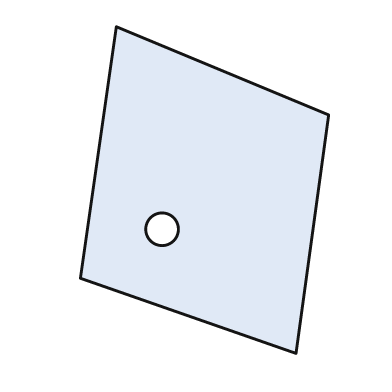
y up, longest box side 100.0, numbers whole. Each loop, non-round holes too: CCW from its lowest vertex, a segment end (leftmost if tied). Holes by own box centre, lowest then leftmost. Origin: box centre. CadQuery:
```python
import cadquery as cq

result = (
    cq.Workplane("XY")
    .moveTo(28.0, -50.0)
    .lineTo(38.0, 23.0)
    .lineTo(-27.0, 50.0)
    .lineTo(-38.0, -27.0)
    .close()
    .moveTo(-13.0, -12.0)
    .circle(5.0)
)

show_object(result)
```